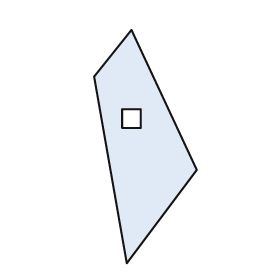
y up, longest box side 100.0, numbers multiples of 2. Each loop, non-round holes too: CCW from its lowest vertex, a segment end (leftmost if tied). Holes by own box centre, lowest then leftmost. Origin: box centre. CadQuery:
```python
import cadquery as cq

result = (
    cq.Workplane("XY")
    .moveTo(-8.0, -50.0)
    .lineTo(22.0, -10.0)
    .lineTo(-6.0, 50.0)
    .lineTo(-22.0, 30.0)
    .close()
    .moveTo(-10.0, 8.0)
    .lineTo(-2.0, 8.0)
    .lineTo(-2.0, 16.0)
    .lineTo(-10.0, 16.0)
    .close()
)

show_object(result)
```